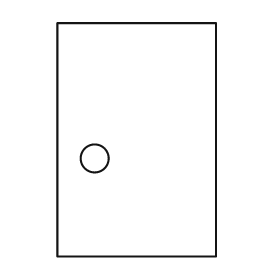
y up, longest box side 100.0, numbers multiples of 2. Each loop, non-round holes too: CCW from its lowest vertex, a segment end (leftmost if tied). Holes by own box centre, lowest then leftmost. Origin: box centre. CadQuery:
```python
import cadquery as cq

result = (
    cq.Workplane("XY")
    .moveTo(-34.0, -50.0)
    .lineTo(34.0, -50.0)
    .lineTo(34.0, 50.0)
    .lineTo(-34.0, 50.0)
    .close()
    .moveTo(-18.0, -8.0)
    .circle(6.0)
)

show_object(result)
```